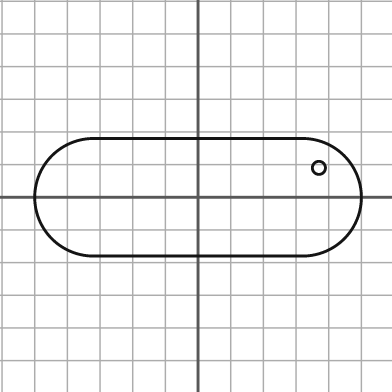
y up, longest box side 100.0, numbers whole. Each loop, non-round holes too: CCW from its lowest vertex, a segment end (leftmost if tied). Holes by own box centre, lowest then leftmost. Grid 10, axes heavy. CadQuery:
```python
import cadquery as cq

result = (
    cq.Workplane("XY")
    .moveTo(-32.0, -18.0)
    .lineTo(32.0, -18.0)
    .threePointArc((50.0, 0.0), (32.0, 18.0))
    .lineTo(-32.0, 18.0)
    .threePointArc((-50.0, 0.0), (-32.0, -18.0))
    .close()
    .moveTo(37.0, 9.0)
    .circle(2.0)
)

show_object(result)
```